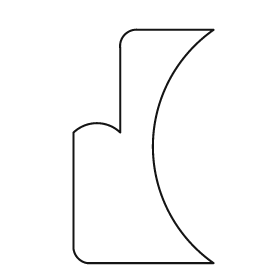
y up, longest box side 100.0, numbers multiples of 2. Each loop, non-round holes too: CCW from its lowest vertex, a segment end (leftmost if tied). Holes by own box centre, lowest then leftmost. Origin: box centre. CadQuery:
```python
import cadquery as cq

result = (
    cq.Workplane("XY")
    .moveTo(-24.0, -50.0)
    .lineTo(30.0, -50.0)
    .threePointArc((4.0, 0.0), (30.0, 50.0))
    .lineTo(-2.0, 50.0)
    .threePointArc((-8.0, 48.0), (-10.0, 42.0))
    .lineTo(-10.0, 6.0)
    .threePointArc((-20.0, 10.0), (-30.0, 6.0))
    .lineTo(-30.0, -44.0)
    .threePointArc((-28.0, -48.0), (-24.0, -50.0))
    .close()
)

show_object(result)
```